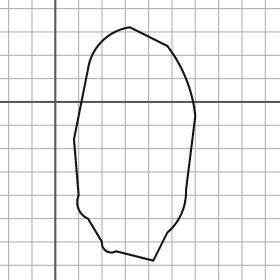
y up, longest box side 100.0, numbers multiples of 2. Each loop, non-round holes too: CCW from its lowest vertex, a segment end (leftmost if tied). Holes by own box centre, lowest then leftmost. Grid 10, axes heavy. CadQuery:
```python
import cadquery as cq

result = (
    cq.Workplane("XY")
    .moveTo(42.0, -68.0)
    .lineTo(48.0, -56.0)
    .threePointArc((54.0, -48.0), (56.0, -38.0))
    .lineTo(60.0, -6.0)
    .threePointArc((56.0, 10.0), (48.0, 24.0))
    .lineTo(32.0, 32.0)
    .threePointArc((20.0, 26.0), (14.0, 14.0))
    .lineTo(8.0, -16.0)
    .lineTo(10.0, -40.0)
    .threePointArc((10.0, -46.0), (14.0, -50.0))
    .lineTo(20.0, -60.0)
    .threePointArc((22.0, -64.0), (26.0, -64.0))
    .close()
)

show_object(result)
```